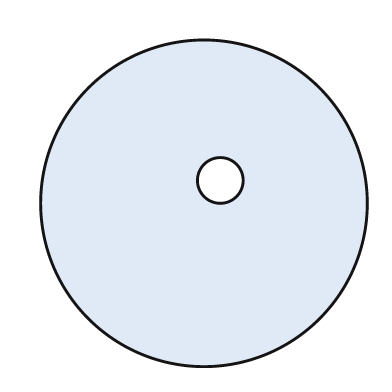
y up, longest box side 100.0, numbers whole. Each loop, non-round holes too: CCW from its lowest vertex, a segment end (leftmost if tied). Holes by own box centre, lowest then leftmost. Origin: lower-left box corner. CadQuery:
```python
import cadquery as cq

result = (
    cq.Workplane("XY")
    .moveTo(50.0, 50.0)
    .circle(50.0)
    .moveTo(55.0, 57.0)
    .circle(7.0)
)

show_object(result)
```